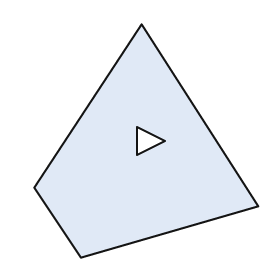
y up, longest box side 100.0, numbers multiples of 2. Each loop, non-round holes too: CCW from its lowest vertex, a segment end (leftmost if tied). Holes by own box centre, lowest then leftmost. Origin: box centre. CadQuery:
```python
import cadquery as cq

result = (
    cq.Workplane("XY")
    .moveTo(-28.0, -50.0)
    .lineTo(48.0, -28.0)
    .lineTo(-2.0, 50.0)
    .lineTo(-48.0, -20.0)
    .close()
    .moveTo(-4.0, -6.0)
    .lineTo(8.0, 0.0)
    .lineTo(-4.0, 6.0)
    .close()
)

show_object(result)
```